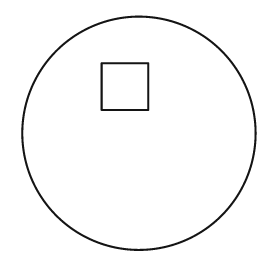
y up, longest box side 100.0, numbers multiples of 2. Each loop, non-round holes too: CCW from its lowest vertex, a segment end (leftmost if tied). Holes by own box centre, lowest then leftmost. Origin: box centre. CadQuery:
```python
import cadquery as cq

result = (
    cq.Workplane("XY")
    .moveTo(0.0, 0.0)
    .circle(50.0)
    .moveTo(-16.0, 10.0)
    .lineTo(4.0, 10.0)
    .lineTo(4.0, 30.0)
    .lineTo(-16.0, 30.0)
    .close()
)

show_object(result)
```